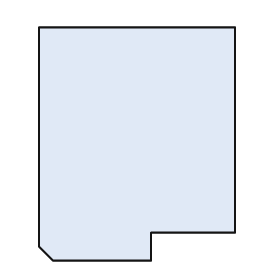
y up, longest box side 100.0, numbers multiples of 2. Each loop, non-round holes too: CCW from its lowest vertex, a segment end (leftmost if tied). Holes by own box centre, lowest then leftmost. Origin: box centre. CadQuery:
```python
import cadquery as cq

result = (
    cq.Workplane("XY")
    .moveTo(-36.0, -50.0)
    .lineTo(6.0, -50.0)
    .lineTo(6.0, -38.0)
    .lineTo(42.0, -38.0)
    .lineTo(42.0, 50.0)
    .lineTo(-42.0, 50.0)
    .lineTo(-42.0, -44.0)
    .close()
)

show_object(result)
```